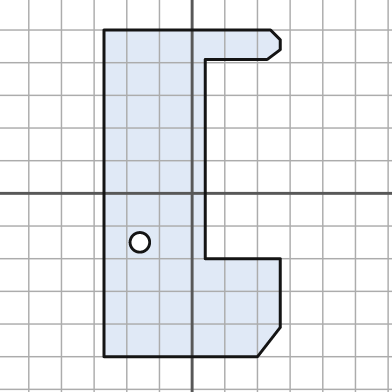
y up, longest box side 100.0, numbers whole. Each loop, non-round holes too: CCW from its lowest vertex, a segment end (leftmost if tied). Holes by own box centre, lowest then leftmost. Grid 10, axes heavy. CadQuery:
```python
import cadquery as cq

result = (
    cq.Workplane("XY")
    .moveTo(-27.0, -50.0)
    .lineTo(20.0, -50.0)
    .lineTo(27.0, -41.0)
    .lineTo(27.0, -20.0)
    .lineTo(4.0, -20.0)
    .lineTo(4.0, 41.0)
    .lineTo(23.0, 41.0)
    .lineTo(27.0, 44.0)
    .lineTo(27.0, 47.0)
    .lineTo(24.0, 50.0)
    .lineTo(-27.0, 50.0)
    .close()
    .moveTo(-16.0, -15.0)
    .circle(3.0)
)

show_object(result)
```